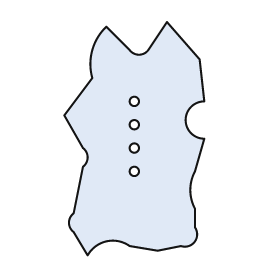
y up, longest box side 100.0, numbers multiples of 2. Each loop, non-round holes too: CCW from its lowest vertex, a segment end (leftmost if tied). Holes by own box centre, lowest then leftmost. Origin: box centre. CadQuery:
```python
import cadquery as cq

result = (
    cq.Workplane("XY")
    .moveTo(-20.0, -50.0)
    .threePointArc((-12.0, -44.0), (-2.0, -46.0))
    .lineTo(10.0, -48.0)
    .lineTo(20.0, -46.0)
    .threePointArc((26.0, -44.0), (26.0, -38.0))
    .lineTo(26.0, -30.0)
    .threePointArc((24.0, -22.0), (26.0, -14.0))
    .lineTo(30.0, 0.0)
    .threePointArc((22.0, 8.0), (30.0, 16.0))
    .lineTo(28.0, 34.0)
    .lineTo(14.0, 50.0)
    .lineTo(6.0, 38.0)
    .threePointArc((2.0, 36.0), (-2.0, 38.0))
    .lineTo(-12.0, 48.0)
    .threePointArc((-18.0, 38.0), (-18.0, 26.0))
    .lineTo(-30.0, 10.0)
    .lineTo(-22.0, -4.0)
    .threePointArc((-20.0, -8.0), (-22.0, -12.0))
    .lineTo(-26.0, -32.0)
    .threePointArc((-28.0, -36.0), (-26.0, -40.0))
    .close()
    .moveTo(0.0, -14.0)
    .circle(2.0)
    .moveTo(0.0, -4.0)
    .circle(2.0)
    .moveTo(0.0, 6.0)
    .circle(2.0)
    .moveTo(0.0, 16.0)
    .circle(2.0)
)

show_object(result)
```